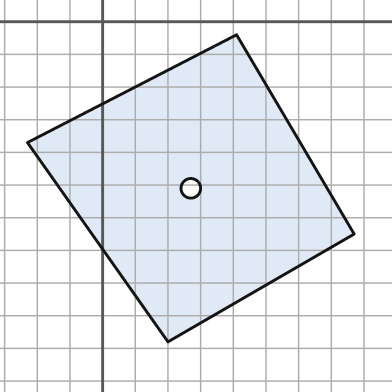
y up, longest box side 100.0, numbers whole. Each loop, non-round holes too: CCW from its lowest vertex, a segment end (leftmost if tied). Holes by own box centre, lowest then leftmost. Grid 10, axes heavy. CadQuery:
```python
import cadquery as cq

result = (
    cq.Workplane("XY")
    .moveTo(20.0, -98.0)
    .lineTo(77.0, -65.0)
    .lineTo(41.0, -4.0)
    .lineTo(-23.0, -37.0)
    .close()
    .moveTo(27.0, -51.0)
    .circle(3.0)
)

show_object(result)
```